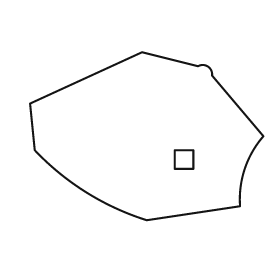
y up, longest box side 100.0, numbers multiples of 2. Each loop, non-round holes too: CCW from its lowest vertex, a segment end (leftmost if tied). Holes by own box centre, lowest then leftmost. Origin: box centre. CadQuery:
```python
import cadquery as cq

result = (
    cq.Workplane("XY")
    .moveTo(0.0, -36.0)
    .lineTo(40.0, -30.0)
    .threePointArc((42.0, -14.0), (50.0, 0.0))
    .lineTo(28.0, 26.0)
    .threePointArc((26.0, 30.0), (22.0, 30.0))
    .lineTo(-2.0, 36.0)
    .lineTo(-50.0, 14.0)
    .lineTo(-48.0, -6.0)
    .threePointArc((-26.0, -24.0), (0.0, -36.0))
    .close()
    .moveTo(12.0, -14.0)
    .lineTo(20.0, -14.0)
    .lineTo(20.0, -6.0)
    .lineTo(12.0, -6.0)
    .close()
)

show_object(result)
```